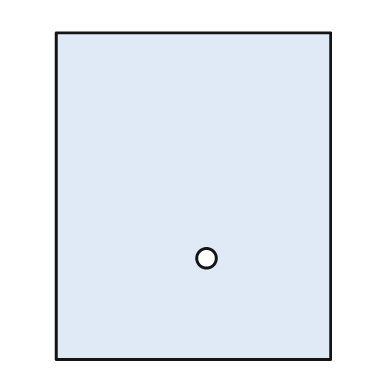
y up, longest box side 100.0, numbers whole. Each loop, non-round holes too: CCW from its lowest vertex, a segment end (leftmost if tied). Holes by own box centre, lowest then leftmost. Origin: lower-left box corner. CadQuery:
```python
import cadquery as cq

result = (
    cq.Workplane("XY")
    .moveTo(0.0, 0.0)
    .lineTo(84.0, 0.0)
    .lineTo(84.0, 100.0)
    .lineTo(0.0, 100.0)
    .close()
    .moveTo(46.0, 31.0)
    .circle(3.0)
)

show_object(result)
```